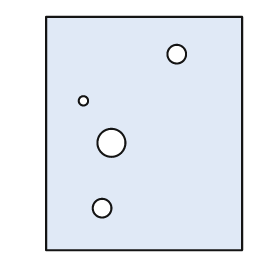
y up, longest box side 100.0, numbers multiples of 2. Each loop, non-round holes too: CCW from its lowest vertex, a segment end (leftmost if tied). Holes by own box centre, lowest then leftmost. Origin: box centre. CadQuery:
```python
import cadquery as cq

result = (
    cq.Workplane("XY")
    .moveTo(-42.0, -50.0)
    .lineTo(42.0, -50.0)
    .lineTo(42.0, 50.0)
    .lineTo(-42.0, 50.0)
    .close()
    .moveTo(-18.0, -32.0)
    .circle(4.0)
    .moveTo(-14.0, -4.0)
    .circle(6.0)
    .moveTo(-26.0, 14.0)
    .circle(2.0)
    .moveTo(14.0, 34.0)
    .circle(4.0)
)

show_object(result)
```